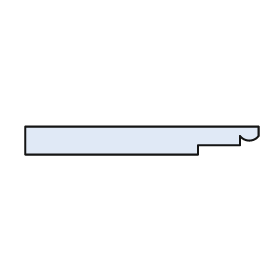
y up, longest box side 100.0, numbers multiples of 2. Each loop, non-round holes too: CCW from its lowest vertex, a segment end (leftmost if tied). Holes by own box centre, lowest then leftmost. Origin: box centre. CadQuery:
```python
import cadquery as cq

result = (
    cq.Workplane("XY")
    .moveTo(-50.0, -6.0)
    .lineTo(24.0, -6.0)
    .lineTo(24.0, -2.0)
    .lineTo(42.0, -2.0)
    .lineTo(42.0, 2.0)
    .threePointArc((46.0, 0.0), (50.0, 2.0))
    .lineTo(50.0, 6.0)
    .lineTo(-50.0, 6.0)
    .close()
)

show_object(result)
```